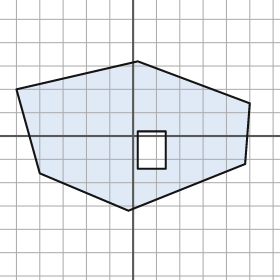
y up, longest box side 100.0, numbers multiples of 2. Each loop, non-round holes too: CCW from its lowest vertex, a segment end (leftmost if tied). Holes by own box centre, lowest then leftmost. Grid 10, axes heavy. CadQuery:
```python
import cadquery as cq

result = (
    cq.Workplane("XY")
    .moveTo(-2.0, -32.0)
    .lineTo(48.0, -12.0)
    .lineTo(50.0, 14.0)
    .lineTo(2.0, 32.0)
    .lineTo(-50.0, 20.0)
    .lineTo(-40.0, -16.0)
    .close()
    .moveTo(2.0, -14.0)
    .lineTo(14.0, -14.0)
    .lineTo(14.0, 2.0)
    .lineTo(2.0, 2.0)
    .close()
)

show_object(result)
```